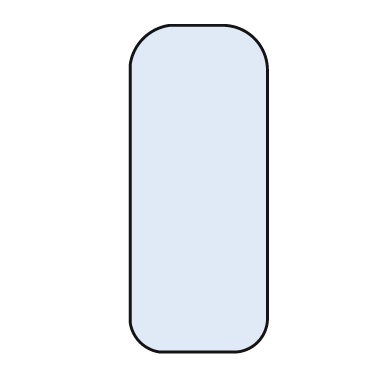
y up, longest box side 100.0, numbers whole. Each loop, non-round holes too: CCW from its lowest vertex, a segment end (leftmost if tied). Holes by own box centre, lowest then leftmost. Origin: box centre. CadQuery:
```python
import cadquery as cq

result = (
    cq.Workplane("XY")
    .moveTo(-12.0, -50.0)
    .lineTo(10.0, -50.0)
    .threePointArc((18.0, -47.0), (21.0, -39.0))
    .lineTo(21.0, 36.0)
    .threePointArc((17.0, 46.0), (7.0, 50.0))
    .lineTo(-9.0, 50.0)
    .threePointArc((-17.0, 46.0), (-21.0, 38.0))
    .lineTo(-21.0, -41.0)
    .threePointArc((-18.0, -47.0), (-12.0, -50.0))
    .close()
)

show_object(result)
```